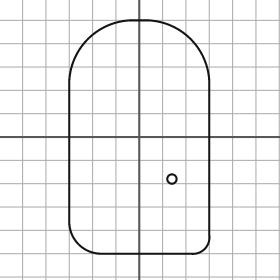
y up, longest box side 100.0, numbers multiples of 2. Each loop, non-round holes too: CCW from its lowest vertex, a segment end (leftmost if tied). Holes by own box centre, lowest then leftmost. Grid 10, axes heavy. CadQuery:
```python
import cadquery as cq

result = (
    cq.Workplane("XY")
    .moveTo(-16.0, -50.0)
    .lineTo(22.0, -50.0)
    .threePointArc((28.0, -48.0), (30.0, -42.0))
    .lineTo(30.0, 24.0)
    .threePointArc((22.0, 42.0), (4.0, 50.0))
    .lineTo(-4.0, 50.0)
    .threePointArc((-22.0, 42.0), (-30.0, 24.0))
    .lineTo(-30.0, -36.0)
    .threePointArc((-26.0, -46.0), (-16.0, -50.0))
    .close()
    .moveTo(14.0, -18.0)
    .circle(2.0)
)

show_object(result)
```